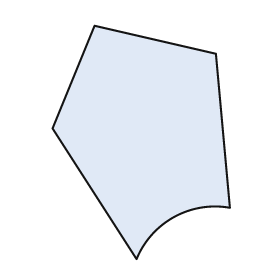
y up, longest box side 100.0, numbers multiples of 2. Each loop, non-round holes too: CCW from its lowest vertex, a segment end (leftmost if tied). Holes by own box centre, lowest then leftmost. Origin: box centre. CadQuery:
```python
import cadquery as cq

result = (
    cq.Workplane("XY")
    .moveTo(-2.0, -50.0)
    .threePointArc((14.0, -32.0), (38.0, -28.0))
    .lineTo(32.0, 38.0)
    .lineTo(-20.0, 50.0)
    .lineTo(-38.0, 6.0)
    .close()
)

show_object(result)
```